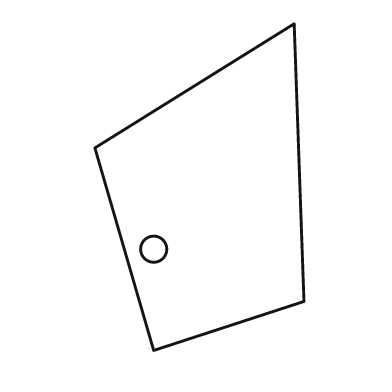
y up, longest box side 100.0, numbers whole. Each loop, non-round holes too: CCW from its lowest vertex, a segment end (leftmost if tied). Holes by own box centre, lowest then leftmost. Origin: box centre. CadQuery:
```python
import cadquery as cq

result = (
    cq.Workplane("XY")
    .moveTo(-14.0, -50.0)
    .lineTo(32.0, -35.0)
    .lineTo(29.0, 50.0)
    .lineTo(-32.0, 12.0)
    .close()
    .moveTo(-14.0, -19.0)
    .circle(4.0)
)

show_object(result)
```